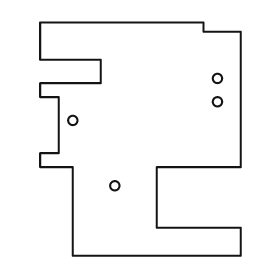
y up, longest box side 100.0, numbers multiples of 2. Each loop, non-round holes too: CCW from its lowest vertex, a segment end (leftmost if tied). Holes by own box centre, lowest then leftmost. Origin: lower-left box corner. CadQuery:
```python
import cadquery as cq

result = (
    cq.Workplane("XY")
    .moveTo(14.0, 0.0)
    .lineTo(86.0, 0.0)
    .lineTo(86.0, 12.0)
    .lineTo(50.0, 12.0)
    .lineTo(50.0, 38.0)
    .lineTo(86.0, 38.0)
    .lineTo(86.0, 96.0)
    .lineTo(70.0, 96.0)
    .lineTo(70.0, 100.0)
    .lineTo(0.0, 100.0)
    .lineTo(0.0, 84.0)
    .lineTo(26.0, 84.0)
    .lineTo(26.0, 74.0)
    .lineTo(0.0, 74.0)
    .lineTo(0.0, 68.0)
    .lineTo(8.0, 68.0)
    .lineTo(8.0, 44.0)
    .lineTo(0.0, 44.0)
    .lineTo(0.0, 38.0)
    .lineTo(14.0, 38.0)
    .close()
    .moveTo(32.0, 30.0)
    .circle(2.0)
    .moveTo(14.0, 58.0)
    .circle(2.0)
    .moveTo(76.0, 66.0)
    .circle(2.0)
    .moveTo(76.0, 76.0)
    .circle(2.0)
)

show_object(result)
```